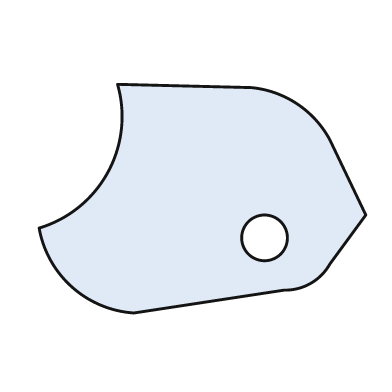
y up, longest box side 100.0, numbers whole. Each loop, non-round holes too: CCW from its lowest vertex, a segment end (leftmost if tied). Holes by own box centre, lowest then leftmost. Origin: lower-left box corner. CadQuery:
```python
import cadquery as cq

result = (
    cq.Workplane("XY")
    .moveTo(29.0, 0.0)
    .lineTo(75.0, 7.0)
    .threePointArc((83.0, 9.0), (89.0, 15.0))
    .lineTo(100.0, 30.0)
    .lineTo(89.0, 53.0)
    .threePointArc((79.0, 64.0), (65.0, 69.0))
    .lineTo(24.0, 70.0)
    .threePointArc((21.0, 43.0), (0.0, 26.0))
    .threePointArc((10.0, 8.0), (29.0, 0.0))
    .close()
    .moveTo(69.0, 23.0)
    .circle(7.0)
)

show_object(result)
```